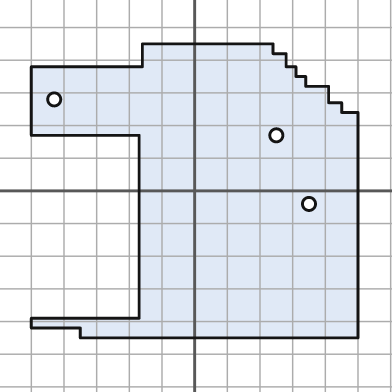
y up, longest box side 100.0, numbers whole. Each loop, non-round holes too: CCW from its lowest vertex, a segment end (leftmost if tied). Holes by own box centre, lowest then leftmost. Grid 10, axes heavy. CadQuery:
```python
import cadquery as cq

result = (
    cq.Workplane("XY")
    .moveTo(-35.0, -45.0)
    .lineTo(50.0, -45.0)
    .lineTo(50.0, 24.0)
    .lineTo(45.0, 24.0)
    .lineTo(45.0, 27.0)
    .lineTo(41.0, 27.0)
    .lineTo(41.0, 32.0)
    .lineTo(34.0, 32.0)
    .lineTo(34.0, 35.0)
    .lineTo(31.0, 35.0)
    .lineTo(31.0, 38.0)
    .lineTo(28.0, 38.0)
    .lineTo(28.0, 42.0)
    .lineTo(24.0, 42.0)
    .lineTo(24.0, 45.0)
    .lineTo(-16.0, 45.0)
    .lineTo(-16.0, 38.0)
    .lineTo(-50.0, 38.0)
    .lineTo(-50.0, 17.0)
    .lineTo(-17.0, 17.0)
    .lineTo(-17.0, -39.0)
    .lineTo(-50.0, -39.0)
    .lineTo(-50.0, -42.0)
    .lineTo(-35.0, -42.0)
    .close()
    .moveTo(35.0, -4.0)
    .circle(2.0)
    .moveTo(25.0, 17.0)
    .circle(2.0)
    .moveTo(-43.0, 28.0)
    .circle(2.0)
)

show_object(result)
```